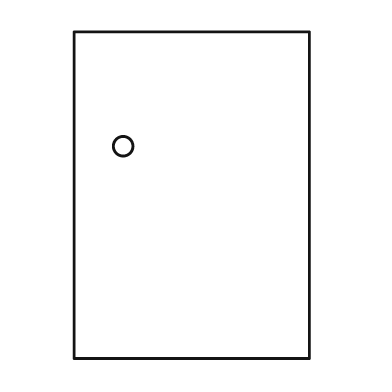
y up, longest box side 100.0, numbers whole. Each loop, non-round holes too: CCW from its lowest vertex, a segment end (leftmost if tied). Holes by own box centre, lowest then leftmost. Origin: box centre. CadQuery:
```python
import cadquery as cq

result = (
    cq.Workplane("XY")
    .moveTo(-36.0, -50.0)
    .lineTo(36.0, -50.0)
    .lineTo(36.0, 50.0)
    .lineTo(-36.0, 50.0)
    .close()
    .moveTo(-21.0, 15.0)
    .circle(3.0)
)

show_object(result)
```